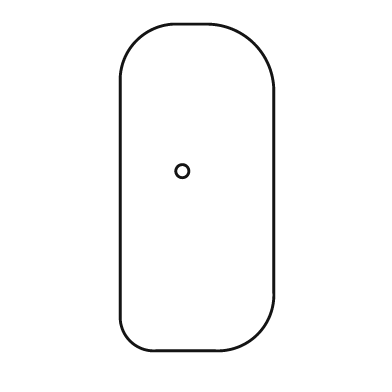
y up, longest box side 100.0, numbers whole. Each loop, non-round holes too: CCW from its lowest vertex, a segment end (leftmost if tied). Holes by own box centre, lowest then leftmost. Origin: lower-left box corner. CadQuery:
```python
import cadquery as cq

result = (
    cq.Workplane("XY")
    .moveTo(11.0, 0.0)
    .lineTo(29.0, 0.0)
    .threePointArc((42.0, 5.0), (47.0, 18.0))
    .lineTo(47.0, 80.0)
    .threePointArc((41.0, 94.0), (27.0, 100.0))
    .lineTo(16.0, 100.0)
    .threePointArc((5.0, 95.0), (0.0, 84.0))
    .lineTo(0.0, 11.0)
    .threePointArc((3.0, 3.0), (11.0, 0.0))
    .close()
    .moveTo(19.0, 55.0)
    .circle(2.0)
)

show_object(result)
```